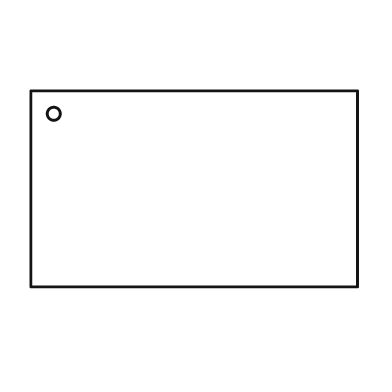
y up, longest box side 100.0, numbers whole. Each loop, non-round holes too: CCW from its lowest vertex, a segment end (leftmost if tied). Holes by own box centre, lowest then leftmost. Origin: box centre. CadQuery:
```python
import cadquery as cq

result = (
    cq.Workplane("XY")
    .moveTo(-50.0, -30.0)
    .lineTo(50.0, -30.0)
    .lineTo(50.0, 30.0)
    .lineTo(-50.0, 30.0)
    .close()
    .moveTo(-43.0, 23.0)
    .circle(2.0)
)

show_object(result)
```